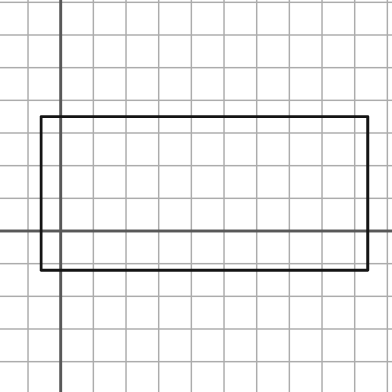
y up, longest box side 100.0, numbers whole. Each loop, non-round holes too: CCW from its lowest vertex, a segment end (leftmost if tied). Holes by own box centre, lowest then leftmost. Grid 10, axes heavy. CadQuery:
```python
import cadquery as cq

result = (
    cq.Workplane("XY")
    .moveTo(-6.0, -12.0)
    .lineTo(94.0, -12.0)
    .lineTo(94.0, 35.0)
    .lineTo(-6.0, 35.0)
    .close()
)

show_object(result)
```